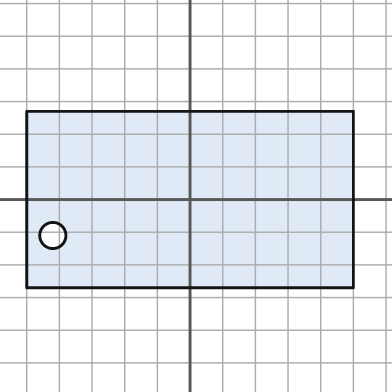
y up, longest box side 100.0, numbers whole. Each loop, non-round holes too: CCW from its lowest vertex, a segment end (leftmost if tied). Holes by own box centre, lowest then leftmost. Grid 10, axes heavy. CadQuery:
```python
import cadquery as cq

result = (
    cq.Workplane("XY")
    .moveTo(-50.0, -27.0)
    .lineTo(50.0, -27.0)
    .lineTo(50.0, 27.0)
    .lineTo(-50.0, 27.0)
    .close()
    .moveTo(-42.0, -11.0)
    .circle(4.0)
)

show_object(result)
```